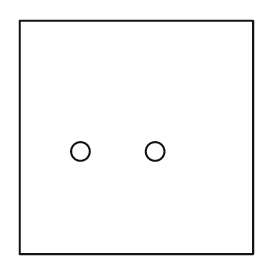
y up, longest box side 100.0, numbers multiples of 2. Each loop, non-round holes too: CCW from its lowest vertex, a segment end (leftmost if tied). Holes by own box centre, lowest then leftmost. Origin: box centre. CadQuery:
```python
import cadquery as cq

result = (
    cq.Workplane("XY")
    .moveTo(-50.0, -50.0)
    .lineTo(50.0, -50.0)
    .lineTo(50.0, 50.0)
    .lineTo(-50.0, 50.0)
    .close()
    .moveTo(-24.0, -6.0)
    .circle(4.0)
    .moveTo(8.0, -6.0)
    .circle(4.0)
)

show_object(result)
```